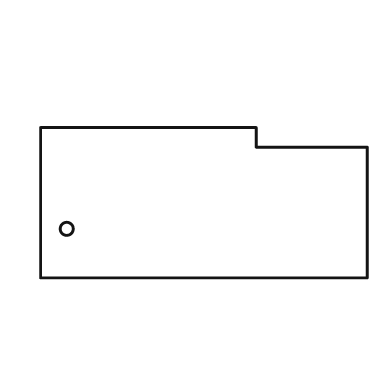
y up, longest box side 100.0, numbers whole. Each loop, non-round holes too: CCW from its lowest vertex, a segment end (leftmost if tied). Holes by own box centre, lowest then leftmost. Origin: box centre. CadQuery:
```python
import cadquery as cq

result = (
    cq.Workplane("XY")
    .moveTo(-50.0, -23.0)
    .lineTo(50.0, -23.0)
    .lineTo(50.0, 17.0)
    .lineTo(16.0, 17.0)
    .lineTo(16.0, 23.0)
    .lineTo(-50.0, 23.0)
    .close()
    .moveTo(-42.0, -8.0)
    .circle(2.0)
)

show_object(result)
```